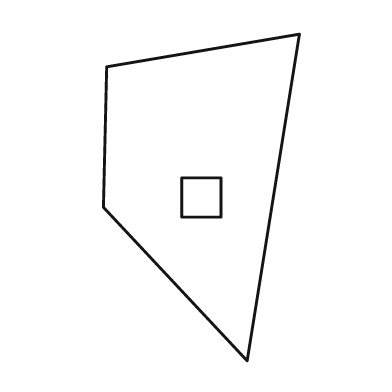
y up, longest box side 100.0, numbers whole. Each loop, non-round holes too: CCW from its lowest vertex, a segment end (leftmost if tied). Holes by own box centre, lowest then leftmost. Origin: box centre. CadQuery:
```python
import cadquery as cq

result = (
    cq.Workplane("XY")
    .moveTo(14.0, -50.0)
    .lineTo(30.0, 50.0)
    .lineTo(-29.0, 40.0)
    .lineTo(-30.0, -3.0)
    .close()
    .moveTo(-6.0, -6.0)
    .lineTo(6.0, -6.0)
    .lineTo(6.0, 6.0)
    .lineTo(-6.0, 6.0)
    .close()
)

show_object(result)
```